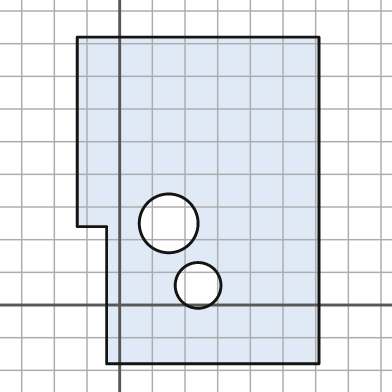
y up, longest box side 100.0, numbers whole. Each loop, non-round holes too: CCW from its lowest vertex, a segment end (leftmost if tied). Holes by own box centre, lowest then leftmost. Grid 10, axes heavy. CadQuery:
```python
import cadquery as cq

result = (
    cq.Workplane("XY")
    .moveTo(-4.0, -18.0)
    .lineTo(61.0, -18.0)
    .lineTo(61.0, 82.0)
    .lineTo(-13.0, 82.0)
    .lineTo(-13.0, 24.0)
    .lineTo(-4.0, 24.0)
    .close()
    .moveTo(24.0, 6.0)
    .circle(7.0)
    .moveTo(15.0, 25.0)
    .circle(9.0)
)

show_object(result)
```